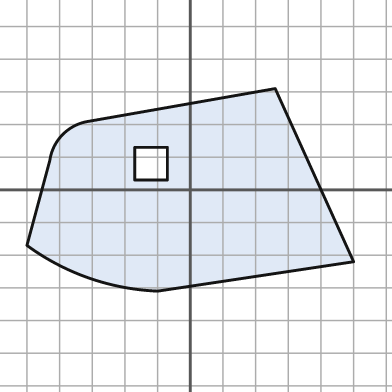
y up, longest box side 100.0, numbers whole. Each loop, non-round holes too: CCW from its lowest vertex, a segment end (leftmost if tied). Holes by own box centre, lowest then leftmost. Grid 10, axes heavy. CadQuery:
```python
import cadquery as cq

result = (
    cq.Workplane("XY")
    .moveTo(-10.0, -31.0)
    .lineTo(50.0, -22.0)
    .lineTo(26.0, 31.0)
    .lineTo(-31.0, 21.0)
    .threePointArc((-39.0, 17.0), (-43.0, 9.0))
    .lineTo(-50.0, -17.0)
    .threePointArc((-31.0, -27.0), (-10.0, -31.0))
    .close()
    .moveTo(-17.0, 3.0)
    .lineTo(-7.0, 3.0)
    .lineTo(-7.0, 13.0)
    .lineTo(-17.0, 13.0)
    .close()
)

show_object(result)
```